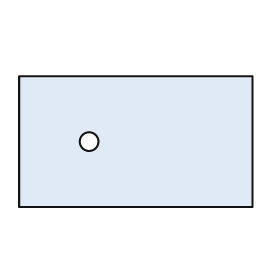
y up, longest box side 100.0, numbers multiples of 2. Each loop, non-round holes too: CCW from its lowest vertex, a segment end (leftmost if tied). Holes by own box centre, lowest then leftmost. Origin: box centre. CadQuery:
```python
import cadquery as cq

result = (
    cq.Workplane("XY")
    .moveTo(-50.0, -28.0)
    .lineTo(50.0, -28.0)
    .lineTo(50.0, 28.0)
    .lineTo(-50.0, 28.0)
    .close()
    .moveTo(-20.0, 0.0)
    .circle(4.0)
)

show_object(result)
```